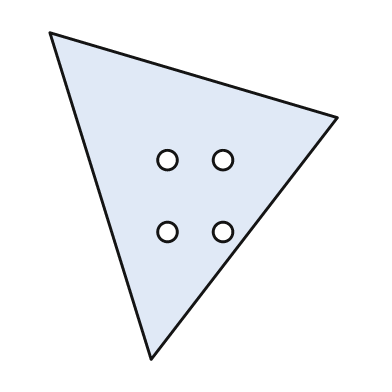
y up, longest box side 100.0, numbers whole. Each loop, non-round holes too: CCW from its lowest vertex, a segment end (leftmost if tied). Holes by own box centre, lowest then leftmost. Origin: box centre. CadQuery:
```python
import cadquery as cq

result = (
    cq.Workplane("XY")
    .moveTo(-13.0, -50.0)
    .lineTo(44.0, 24.0)
    .lineTo(-44.0, 50.0)
    .close()
    .moveTo(-8.0, -11.0)
    .circle(3.0)
    .moveTo(9.0, -11.0)
    .circle(3.0)
    .moveTo(-8.0, 11.0)
    .circle(3.0)
    .moveTo(9.0, 11.0)
    .circle(3.0)
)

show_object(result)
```